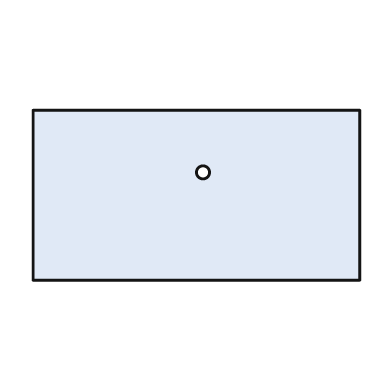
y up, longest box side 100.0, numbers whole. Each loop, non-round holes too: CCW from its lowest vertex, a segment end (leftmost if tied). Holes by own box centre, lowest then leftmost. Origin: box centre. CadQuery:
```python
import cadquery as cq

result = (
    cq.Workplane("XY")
    .moveTo(-50.0, -26.0)
    .lineTo(50.0, -26.0)
    .lineTo(50.0, 26.0)
    .lineTo(-50.0, 26.0)
    .close()
    .moveTo(2.0, 7.0)
    .circle(2.0)
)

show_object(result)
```